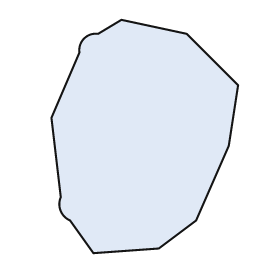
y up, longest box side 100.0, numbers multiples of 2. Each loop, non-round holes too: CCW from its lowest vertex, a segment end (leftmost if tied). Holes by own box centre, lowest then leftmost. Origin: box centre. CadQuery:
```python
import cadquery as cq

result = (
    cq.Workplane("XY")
    .moveTo(-22.0, -50.0)
    .lineTo(6.0, -48.0)
    .lineTo(22.0, -36.0)
    .lineTo(36.0, -4.0)
    .lineTo(40.0, 22.0)
    .lineTo(18.0, 44.0)
    .lineTo(-10.0, 50.0)
    .lineTo(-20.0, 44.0)
    .threePointArc((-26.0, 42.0), (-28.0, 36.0))
    .lineTo(-40.0, 8.0)
    .lineTo(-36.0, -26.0)
    .threePointArc((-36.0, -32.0), (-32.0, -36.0))
    .close()
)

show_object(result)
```